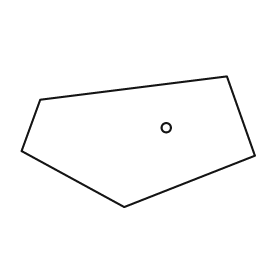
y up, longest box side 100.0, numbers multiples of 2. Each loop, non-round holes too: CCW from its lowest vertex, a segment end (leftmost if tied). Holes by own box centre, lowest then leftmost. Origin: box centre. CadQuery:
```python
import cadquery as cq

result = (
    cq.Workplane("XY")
    .moveTo(-6.0, -28.0)
    .lineTo(50.0, -6.0)
    .lineTo(38.0, 28.0)
    .lineTo(-42.0, 18.0)
    .lineTo(-50.0, -4.0)
    .close()
    .moveTo(12.0, 6.0)
    .circle(2.0)
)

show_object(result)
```